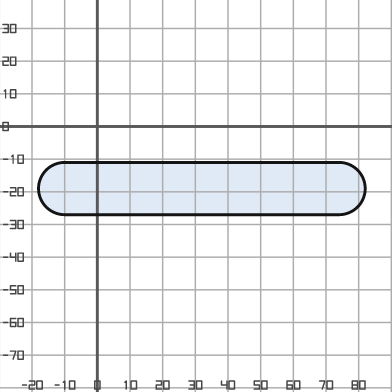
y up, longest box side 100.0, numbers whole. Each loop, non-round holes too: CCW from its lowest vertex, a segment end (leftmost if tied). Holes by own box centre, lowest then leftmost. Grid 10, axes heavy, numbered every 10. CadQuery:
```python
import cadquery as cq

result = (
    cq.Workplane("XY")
    .moveTo(-10.0, -27.0)
    .lineTo(74.0, -27.0)
    .threePointArc((82.0, -19.0), (74.0, -11.0))
    .lineTo(-10.0, -11.0)
    .threePointArc((-18.0, -19.0), (-10.0, -27.0))
    .close()
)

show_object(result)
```